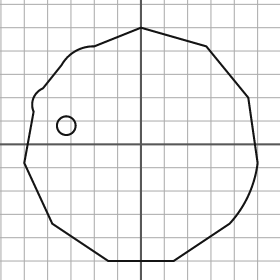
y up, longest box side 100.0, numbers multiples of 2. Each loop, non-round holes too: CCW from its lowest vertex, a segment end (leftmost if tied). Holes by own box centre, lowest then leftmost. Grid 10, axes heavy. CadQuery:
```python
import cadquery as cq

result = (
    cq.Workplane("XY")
    .moveTo(-14.0, -50.0)
    .lineTo(14.0, -50.0)
    .lineTo(38.0, -34.0)
    .threePointArc((46.0, -22.0), (50.0, -8.0))
    .lineTo(46.0, 20.0)
    .lineTo(28.0, 42.0)
    .lineTo(0.0, 50.0)
    .lineTo(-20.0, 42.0)
    .threePointArc((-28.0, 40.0), (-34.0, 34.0))
    .lineTo(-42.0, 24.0)
    .threePointArc((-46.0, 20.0), (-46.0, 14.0))
    .lineTo(-50.0, -8.0)
    .lineTo(-38.0, -34.0)
    .close()
    .moveTo(-32.0, 8.0)
    .circle(4.0)
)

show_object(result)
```